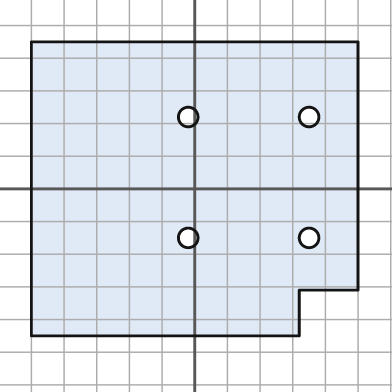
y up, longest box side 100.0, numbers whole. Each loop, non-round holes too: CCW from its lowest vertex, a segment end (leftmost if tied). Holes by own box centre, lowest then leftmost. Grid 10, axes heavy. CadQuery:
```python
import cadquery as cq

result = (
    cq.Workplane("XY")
    .moveTo(-50.0, -45.0)
    .lineTo(32.0, -45.0)
    .lineTo(32.0, -31.0)
    .lineTo(50.0, -31.0)
    .lineTo(50.0, 45.0)
    .lineTo(-50.0, 45.0)
    .close()
    .moveTo(-2.0, -15.0)
    .circle(3.0)
    .moveTo(35.0, -15.0)
    .circle(3.0)
    .moveTo(-2.0, 22.0)
    .circle(3.0)
    .moveTo(35.0, 22.0)
    .circle(3.0)
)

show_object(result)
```